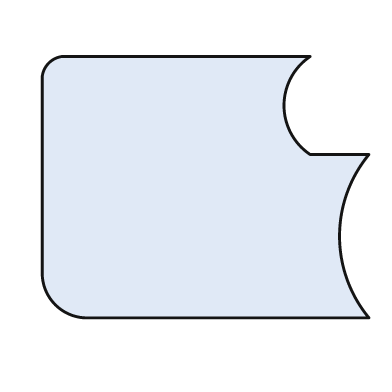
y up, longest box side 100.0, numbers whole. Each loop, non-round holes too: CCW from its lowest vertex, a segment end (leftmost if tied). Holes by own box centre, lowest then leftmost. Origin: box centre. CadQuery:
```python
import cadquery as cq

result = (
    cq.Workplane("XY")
    .moveTo(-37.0, -40.0)
    .lineTo(50.0, -40.0)
    .threePointArc((41.0, -15.0), (50.0, 10.0))
    .lineTo(32.0, 10.0)
    .threePointArc((24.0, 25.0), (32.0, 40.0))
    .lineTo(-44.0, 40.0)
    .threePointArc((-48.0, 38.0), (-50.0, 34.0))
    .lineTo(-50.0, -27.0)
    .threePointArc((-46.0, -36.0), (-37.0, -40.0))
    .close()
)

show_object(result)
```